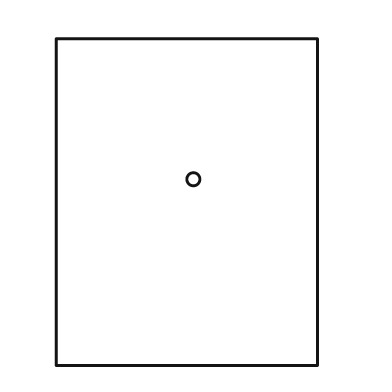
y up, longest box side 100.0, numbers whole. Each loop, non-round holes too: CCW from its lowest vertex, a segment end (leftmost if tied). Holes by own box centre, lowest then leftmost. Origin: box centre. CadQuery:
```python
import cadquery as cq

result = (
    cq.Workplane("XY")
    .moveTo(-40.0, -50.0)
    .lineTo(40.0, -50.0)
    .lineTo(40.0, 50.0)
    .lineTo(-40.0, 50.0)
    .close()
    .moveTo(2.0, 7.0)
    .circle(2.0)
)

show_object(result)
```